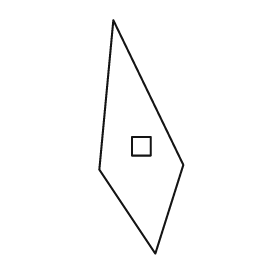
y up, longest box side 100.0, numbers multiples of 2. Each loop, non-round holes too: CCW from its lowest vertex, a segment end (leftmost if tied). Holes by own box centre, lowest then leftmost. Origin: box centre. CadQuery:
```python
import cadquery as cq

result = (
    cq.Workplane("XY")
    .moveTo(6.0, -50.0)
    .lineTo(18.0, -12.0)
    .lineTo(-12.0, 50.0)
    .lineTo(-18.0, -14.0)
    .close()
    .moveTo(-4.0, -8.0)
    .lineTo(4.0, -8.0)
    .lineTo(4.0, 0.0)
    .lineTo(-4.0, 0.0)
    .close()
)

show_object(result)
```